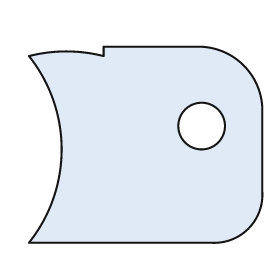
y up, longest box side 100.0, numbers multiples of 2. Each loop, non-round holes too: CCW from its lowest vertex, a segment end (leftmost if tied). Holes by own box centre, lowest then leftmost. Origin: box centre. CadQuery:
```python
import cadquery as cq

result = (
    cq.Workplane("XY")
    .moveTo(-50.0, -42.0)
    .lineTo(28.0, -42.0)
    .threePointArc((44.0, -36.0), (50.0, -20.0))
    .lineTo(50.0, 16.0)
    .threePointArc((42.0, 34.0), (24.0, 42.0))
    .lineTo(-18.0, 42.0)
    .lineTo(-18.0, 38.0)
    .threePointArc((-34.0, 40.0), (-50.0, 38.0))
    .threePointArc((-36.0, -2.0), (-50.0, -42.0))
    .close()
    .moveTo(24.0, 8.0)
    .circle(10.0)
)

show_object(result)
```